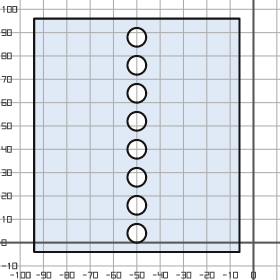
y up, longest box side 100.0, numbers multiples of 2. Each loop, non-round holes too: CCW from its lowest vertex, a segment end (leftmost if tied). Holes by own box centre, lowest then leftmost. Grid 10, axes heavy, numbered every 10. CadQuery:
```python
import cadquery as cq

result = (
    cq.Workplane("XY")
    .moveTo(-94.0, -4.0)
    .lineTo(-6.0, -4.0)
    .lineTo(-6.0, 96.0)
    .lineTo(-94.0, 96.0)
    .close()
    .moveTo(-50.0, 4.0)
    .circle(4.0)
    .moveTo(-50.0, 16.0)
    .circle(4.0)
    .moveTo(-50.0, 28.0)
    .circle(4.0)
    .moveTo(-50.0, 40.0)
    .circle(4.0)
    .moveTo(-50.0, 52.0)
    .circle(4.0)
    .moveTo(-50.0, 64.0)
    .circle(4.0)
    .moveTo(-50.0, 76.0)
    .circle(4.0)
    .moveTo(-50.0, 88.0)
    .circle(4.0)
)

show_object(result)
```